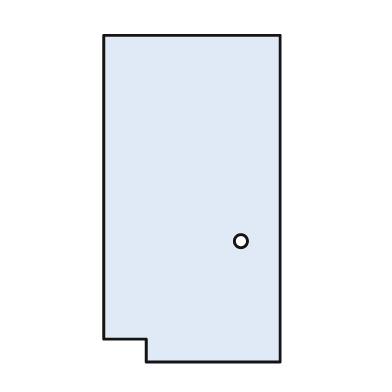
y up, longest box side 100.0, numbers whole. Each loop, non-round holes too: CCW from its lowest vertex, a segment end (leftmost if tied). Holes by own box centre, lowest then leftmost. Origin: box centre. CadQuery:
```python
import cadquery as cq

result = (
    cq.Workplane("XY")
    .moveTo(-14.0, -50.0)
    .lineTo(27.0, -50.0)
    .lineTo(27.0, 50.0)
    .lineTo(-27.0, 50.0)
    .lineTo(-27.0, -43.0)
    .lineTo(-14.0, -43.0)
    .close()
    .moveTo(15.0, -13.0)
    .circle(2.0)
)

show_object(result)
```